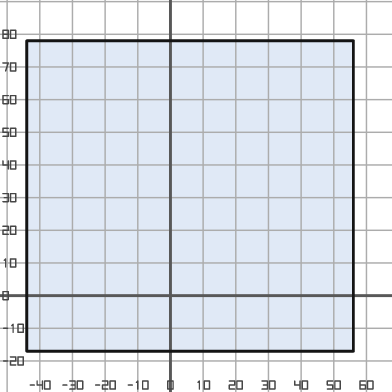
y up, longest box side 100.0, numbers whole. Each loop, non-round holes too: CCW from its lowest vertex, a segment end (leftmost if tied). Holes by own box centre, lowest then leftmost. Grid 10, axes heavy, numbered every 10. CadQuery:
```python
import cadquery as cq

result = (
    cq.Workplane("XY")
    .moveTo(-44.0, -17.0)
    .lineTo(56.0, -17.0)
    .lineTo(56.0, 78.0)
    .lineTo(-44.0, 78.0)
    .close()
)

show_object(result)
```